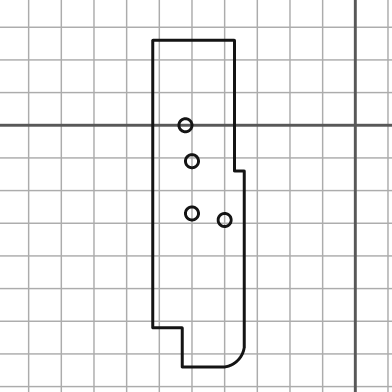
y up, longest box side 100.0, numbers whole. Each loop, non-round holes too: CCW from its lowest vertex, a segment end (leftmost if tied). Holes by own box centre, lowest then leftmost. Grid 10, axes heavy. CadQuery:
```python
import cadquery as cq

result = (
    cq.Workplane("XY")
    .moveTo(-53.0, -74.0)
    .lineTo(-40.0, -74.0)
    .threePointArc((-36.0, -72.0), (-34.0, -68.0))
    .lineTo(-34.0, -14.0)
    .lineTo(-37.0, -14.0)
    .lineTo(-37.0, 26.0)
    .lineTo(-62.0, 26.0)
    .lineTo(-62.0, -62.0)
    .lineTo(-53.0, -62.0)
    .close()
    .moveTo(-40.0, -29.0)
    .circle(2.0)
    .moveTo(-50.0, -27.0)
    .circle(2.0)
    .moveTo(-50.0, -11.0)
    .circle(2.0)
    .moveTo(-52.0, 0.0)
    .circle(2.0)
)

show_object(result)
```